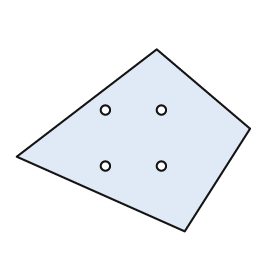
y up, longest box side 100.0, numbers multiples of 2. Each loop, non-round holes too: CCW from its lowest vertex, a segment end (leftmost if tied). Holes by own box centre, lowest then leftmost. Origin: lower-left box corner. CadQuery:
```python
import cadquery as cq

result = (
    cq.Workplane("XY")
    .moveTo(72.0, 0.0)
    .lineTo(100.0, 44.0)
    .lineTo(60.0, 78.0)
    .lineTo(0.0, 32.0)
    .close()
    .moveTo(38.0, 28.0)
    .circle(2.0)
    .moveTo(62.0, 28.0)
    .circle(2.0)
    .moveTo(38.0, 52.0)
    .circle(2.0)
    .moveTo(62.0, 52.0)
    .circle(2.0)
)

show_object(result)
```